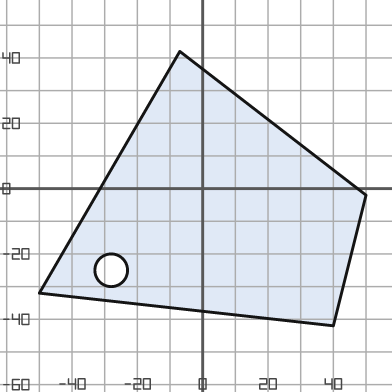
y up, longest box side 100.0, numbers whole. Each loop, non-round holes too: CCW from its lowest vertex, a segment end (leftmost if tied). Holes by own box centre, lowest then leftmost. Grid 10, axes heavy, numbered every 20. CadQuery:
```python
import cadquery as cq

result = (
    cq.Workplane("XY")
    .moveTo(40.0, -42.0)
    .lineTo(50.0, -2.0)
    .lineTo(-7.0, 42.0)
    .lineTo(-50.0, -32.0)
    .close()
    .moveTo(-28.0, -25.0)
    .circle(5.0)
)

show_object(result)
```